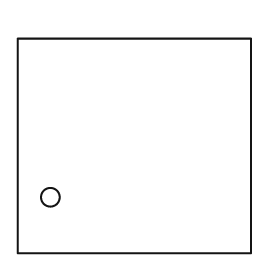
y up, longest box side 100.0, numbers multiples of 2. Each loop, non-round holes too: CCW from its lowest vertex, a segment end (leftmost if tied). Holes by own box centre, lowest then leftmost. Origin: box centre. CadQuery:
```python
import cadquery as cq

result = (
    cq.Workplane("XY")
    .moveTo(-50.0, -46.0)
    .lineTo(50.0, -46.0)
    .lineTo(50.0, 46.0)
    .lineTo(-50.0, 46.0)
    .close()
    .moveTo(-36.0, -22.0)
    .circle(4.0)
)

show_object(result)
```